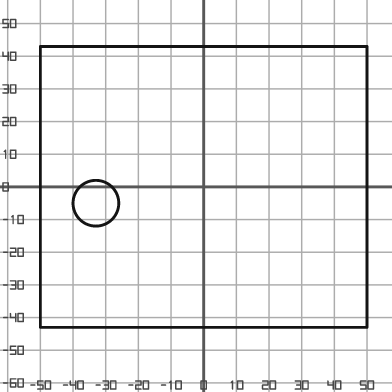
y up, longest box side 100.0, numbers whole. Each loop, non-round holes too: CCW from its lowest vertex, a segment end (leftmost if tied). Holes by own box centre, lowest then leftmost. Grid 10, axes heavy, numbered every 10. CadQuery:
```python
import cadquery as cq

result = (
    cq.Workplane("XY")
    .moveTo(-50.0, -43.0)
    .lineTo(50.0, -43.0)
    .lineTo(50.0, 43.0)
    .lineTo(-50.0, 43.0)
    .close()
    .moveTo(-33.0, -5.0)
    .circle(7.0)
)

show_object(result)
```